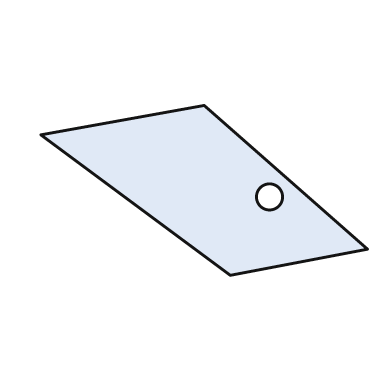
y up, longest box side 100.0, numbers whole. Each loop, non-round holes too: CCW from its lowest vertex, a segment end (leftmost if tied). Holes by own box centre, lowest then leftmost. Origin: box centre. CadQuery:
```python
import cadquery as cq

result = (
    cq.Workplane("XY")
    .moveTo(8.0, -26.0)
    .lineTo(50.0, -18.0)
    .lineTo(0.0, 26.0)
    .lineTo(-50.0, 17.0)
    .close()
    .moveTo(20.0, -2.0)
    .circle(4.0)
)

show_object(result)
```